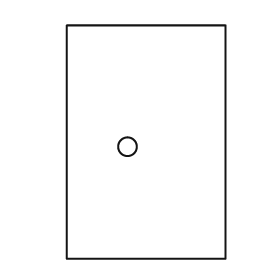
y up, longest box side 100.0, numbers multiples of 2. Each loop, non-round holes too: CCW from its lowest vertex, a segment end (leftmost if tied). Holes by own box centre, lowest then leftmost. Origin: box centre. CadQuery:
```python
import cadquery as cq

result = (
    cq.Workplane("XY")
    .moveTo(-34.0, -50.0)
    .lineTo(34.0, -50.0)
    .lineTo(34.0, 50.0)
    .lineTo(-34.0, 50.0)
    .close()
    .moveTo(-8.0, -2.0)
    .circle(4.0)
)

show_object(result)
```